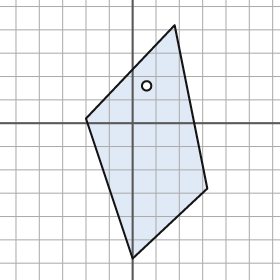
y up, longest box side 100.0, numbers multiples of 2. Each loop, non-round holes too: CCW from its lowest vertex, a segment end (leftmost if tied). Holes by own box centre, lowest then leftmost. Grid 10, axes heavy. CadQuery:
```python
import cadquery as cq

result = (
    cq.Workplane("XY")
    .moveTo(0.0, -58.0)
    .lineTo(32.0, -28.0)
    .lineTo(18.0, 42.0)
    .lineTo(-20.0, 2.0)
    .close()
    .moveTo(6.0, 16.0)
    .circle(2.0)
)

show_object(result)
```